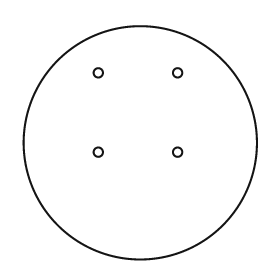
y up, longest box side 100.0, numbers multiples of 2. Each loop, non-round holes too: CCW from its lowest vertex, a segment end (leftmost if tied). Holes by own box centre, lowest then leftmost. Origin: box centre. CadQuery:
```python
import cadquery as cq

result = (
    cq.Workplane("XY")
    .moveTo(0.0, 0.0)
    .circle(50.0)
    .moveTo(-18.0, -4.0)
    .circle(2.0)
    .moveTo(16.0, -4.0)
    .circle(2.0)
    .moveTo(-18.0, 30.0)
    .circle(2.0)
    .moveTo(16.0, 30.0)
    .circle(2.0)
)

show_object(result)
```